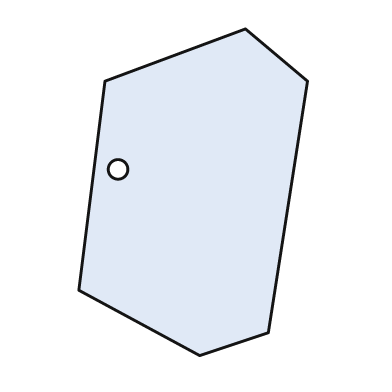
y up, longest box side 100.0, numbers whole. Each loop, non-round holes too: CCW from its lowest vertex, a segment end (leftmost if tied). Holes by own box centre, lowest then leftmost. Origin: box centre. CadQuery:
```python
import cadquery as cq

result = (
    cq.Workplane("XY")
    .moveTo(2.0, -50.0)
    .lineTo(23.0, -43.0)
    .lineTo(35.0, 34.0)
    .lineTo(16.0, 50.0)
    .lineTo(-27.0, 34.0)
    .lineTo(-35.0, -30.0)
    .close()
    .moveTo(-23.0, 7.0)
    .circle(3.0)
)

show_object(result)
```